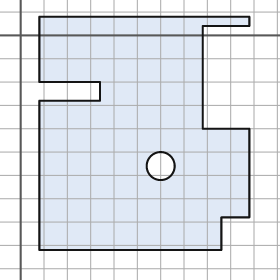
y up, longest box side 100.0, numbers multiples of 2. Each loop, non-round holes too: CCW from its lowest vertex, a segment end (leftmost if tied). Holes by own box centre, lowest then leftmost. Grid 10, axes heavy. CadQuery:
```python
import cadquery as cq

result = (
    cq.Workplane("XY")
    .moveTo(8.0, -92.0)
    .lineTo(86.0, -92.0)
    .lineTo(86.0, -78.0)
    .lineTo(98.0, -78.0)
    .lineTo(98.0, -40.0)
    .lineTo(78.0, -40.0)
    .lineTo(78.0, 4.0)
    .lineTo(98.0, 4.0)
    .lineTo(98.0, 8.0)
    .lineTo(8.0, 8.0)
    .lineTo(8.0, -20.0)
    .lineTo(34.0, -20.0)
    .lineTo(34.0, -28.0)
    .lineTo(8.0, -28.0)
    .close()
    .moveTo(60.0, -56.0)
    .circle(6.0)
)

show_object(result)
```